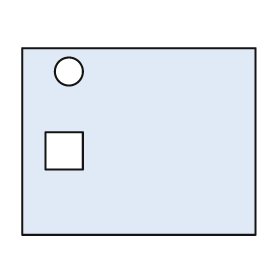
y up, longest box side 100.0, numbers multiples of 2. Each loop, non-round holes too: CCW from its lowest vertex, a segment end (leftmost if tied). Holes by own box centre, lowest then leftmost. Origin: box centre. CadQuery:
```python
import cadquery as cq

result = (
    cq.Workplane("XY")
    .moveTo(-50.0, -40.0)
    .lineTo(50.0, -40.0)
    .lineTo(50.0, 40.0)
    .lineTo(-50.0, 40.0)
    .close()
    .moveTo(-40.0, -12.0)
    .lineTo(-24.0, -12.0)
    .lineTo(-24.0, 4.0)
    .lineTo(-40.0, 4.0)
    .close()
    .moveTo(-30.0, 30.0)
    .circle(6.0)
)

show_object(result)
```